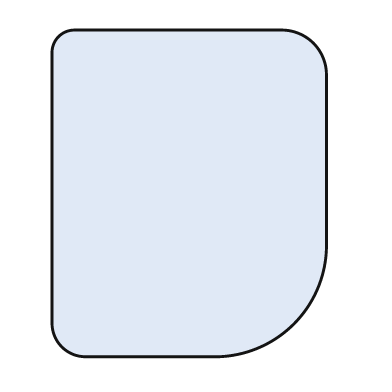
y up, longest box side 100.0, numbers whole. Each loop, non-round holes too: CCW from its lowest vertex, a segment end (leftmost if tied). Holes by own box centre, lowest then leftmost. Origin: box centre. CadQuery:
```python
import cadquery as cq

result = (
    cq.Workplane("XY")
    .moveTo(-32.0, -50.0)
    .lineTo(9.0, -50.0)
    .threePointArc((32.0, -40.0), (42.0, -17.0))
    .lineTo(42.0, 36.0)
    .threePointArc((38.0, 46.0), (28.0, 50.0))
    .lineTo(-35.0, 50.0)
    .threePointArc((-40.0, 48.0), (-42.0, 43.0))
    .lineTo(-42.0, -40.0)
    .threePointArc((-39.0, -47.0), (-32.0, -50.0))
    .close()
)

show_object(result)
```